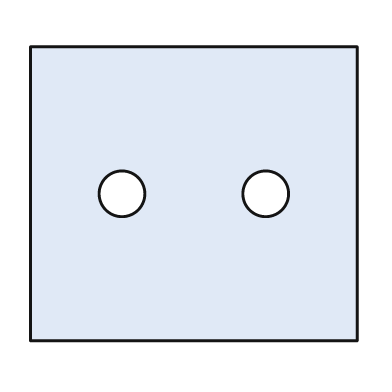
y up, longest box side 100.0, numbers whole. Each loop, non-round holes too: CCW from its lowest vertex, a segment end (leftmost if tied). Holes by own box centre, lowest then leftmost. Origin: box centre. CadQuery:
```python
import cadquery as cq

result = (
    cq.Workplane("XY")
    .moveTo(-50.0, -45.0)
    .lineTo(50.0, -45.0)
    .lineTo(50.0, 45.0)
    .lineTo(-50.0, 45.0)
    .close()
    .moveTo(-22.0, 0.0)
    .circle(7.0)
    .moveTo(22.0, 0.0)
    .circle(7.0)
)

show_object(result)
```